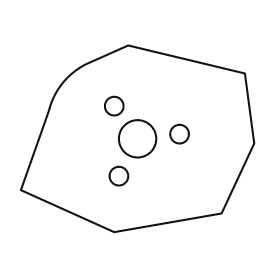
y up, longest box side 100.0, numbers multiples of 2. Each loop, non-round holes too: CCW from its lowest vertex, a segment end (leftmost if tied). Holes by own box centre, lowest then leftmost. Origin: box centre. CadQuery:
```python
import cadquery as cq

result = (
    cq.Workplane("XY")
    .moveTo(-10.0, -40.0)
    .lineTo(36.0, -32.0)
    .lineTo(50.0, -2.0)
    .lineTo(46.0, 28.0)
    .lineTo(-4.0, 40.0)
    .lineTo(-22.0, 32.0)
    .threePointArc((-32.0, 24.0), (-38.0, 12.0))
    .lineTo(-50.0, -22.0)
    .close()
    .moveTo(-8.0, -16.0)
    .circle(4.0)
    .moveTo(0.0, 0.0)
    .circle(8.0)
    .moveTo(18.0, 2.0)
    .circle(4.0)
    .moveTo(-10.0, 14.0)
    .circle(4.0)
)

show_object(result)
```